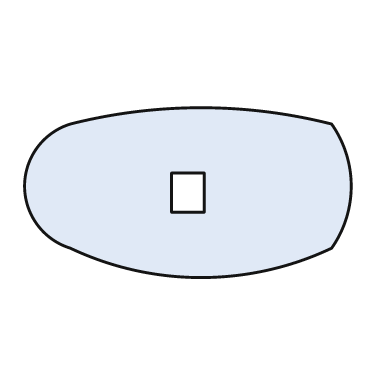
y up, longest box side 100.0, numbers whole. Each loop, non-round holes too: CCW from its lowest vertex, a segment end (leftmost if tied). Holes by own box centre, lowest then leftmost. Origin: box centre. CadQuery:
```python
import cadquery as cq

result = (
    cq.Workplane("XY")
    .moveTo(-36.0, -17.0)
    .threePointArc((4.0, -26.0), (44.0, -17.0))
    .threePointArc((50.0, 2.0), (44.0, 21.0))
    .threePointArc((4.0, 26.0), (-36.0, 21.0))
    .threePointArc((-50.0, 2.0), (-36.0, -17.0))
    .close()
    .moveTo(-5.0, -6.0)
    .lineTo(5.0, -6.0)
    .lineTo(5.0, 6.0)
    .lineTo(-5.0, 6.0)
    .close()
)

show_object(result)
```